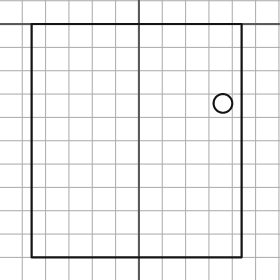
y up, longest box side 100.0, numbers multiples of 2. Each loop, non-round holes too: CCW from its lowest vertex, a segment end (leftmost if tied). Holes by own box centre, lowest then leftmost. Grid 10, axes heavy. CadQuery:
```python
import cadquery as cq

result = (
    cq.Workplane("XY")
    .moveTo(-46.0, -100.0)
    .lineTo(44.0, -100.0)
    .lineTo(44.0, 0.0)
    .lineTo(-46.0, 0.0)
    .close()
    .moveTo(36.0, -34.0)
    .circle(4.0)
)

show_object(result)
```